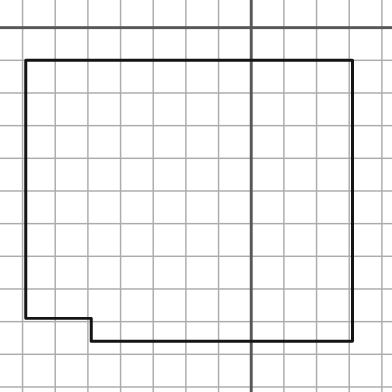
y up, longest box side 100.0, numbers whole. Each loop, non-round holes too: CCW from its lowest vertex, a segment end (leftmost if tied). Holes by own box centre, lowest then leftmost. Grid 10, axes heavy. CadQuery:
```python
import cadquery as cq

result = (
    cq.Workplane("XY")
    .moveTo(-49.0, -96.0)
    .lineTo(31.0, -96.0)
    .lineTo(31.0, -10.0)
    .lineTo(-69.0, -10.0)
    .lineTo(-69.0, -89.0)
    .lineTo(-49.0, -89.0)
    .close()
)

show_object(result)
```